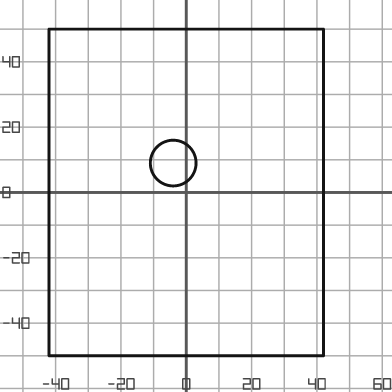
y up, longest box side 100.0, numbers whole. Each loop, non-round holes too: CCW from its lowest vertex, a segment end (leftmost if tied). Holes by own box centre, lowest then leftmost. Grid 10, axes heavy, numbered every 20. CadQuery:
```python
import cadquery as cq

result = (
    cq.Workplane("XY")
    .moveTo(-42.0, -50.0)
    .lineTo(42.0, -50.0)
    .lineTo(42.0, 50.0)
    .lineTo(-42.0, 50.0)
    .close()
    .moveTo(-4.0, 9.0)
    .circle(7.0)
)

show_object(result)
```